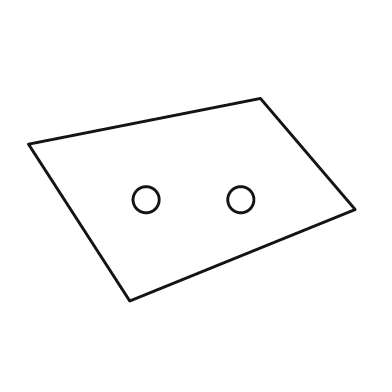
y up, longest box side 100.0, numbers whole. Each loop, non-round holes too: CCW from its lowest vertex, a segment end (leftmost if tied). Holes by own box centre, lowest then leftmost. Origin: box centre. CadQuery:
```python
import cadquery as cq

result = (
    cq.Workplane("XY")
    .moveTo(-19.0, -31.0)
    .lineTo(50.0, -3.0)
    .lineTo(21.0, 31.0)
    .lineTo(-50.0, 17.0)
    .close()
    .moveTo(-14.0, 0.0)
    .circle(4.0)
    .moveTo(15.0, 0.0)
    .circle(4.0)
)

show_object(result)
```